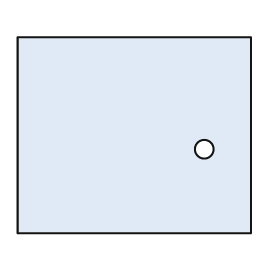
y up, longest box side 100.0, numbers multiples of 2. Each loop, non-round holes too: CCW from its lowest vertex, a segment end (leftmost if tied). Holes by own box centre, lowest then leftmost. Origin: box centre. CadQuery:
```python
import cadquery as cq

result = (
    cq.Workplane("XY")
    .moveTo(-50.0, -42.0)
    .lineTo(50.0, -42.0)
    .lineTo(50.0, 42.0)
    .lineTo(-50.0, 42.0)
    .close()
    .moveTo(30.0, -6.0)
    .circle(4.0)
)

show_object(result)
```